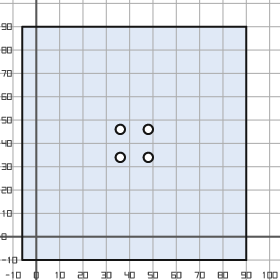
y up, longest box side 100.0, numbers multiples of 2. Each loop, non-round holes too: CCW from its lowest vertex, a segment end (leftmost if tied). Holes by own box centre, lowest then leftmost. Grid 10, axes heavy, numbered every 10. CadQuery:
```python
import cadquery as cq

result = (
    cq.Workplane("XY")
    .moveTo(-6.0, -10.0)
    .lineTo(90.0, -10.0)
    .lineTo(90.0, 90.0)
    .lineTo(-6.0, 90.0)
    .close()
    .moveTo(36.0, 34.0)
    .circle(2.0)
    .moveTo(48.0, 34.0)
    .circle(2.0)
    .moveTo(36.0, 46.0)
    .circle(2.0)
    .moveTo(48.0, 46.0)
    .circle(2.0)
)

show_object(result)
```